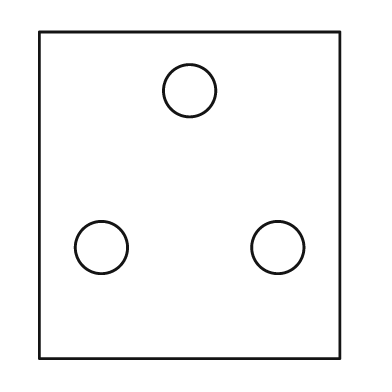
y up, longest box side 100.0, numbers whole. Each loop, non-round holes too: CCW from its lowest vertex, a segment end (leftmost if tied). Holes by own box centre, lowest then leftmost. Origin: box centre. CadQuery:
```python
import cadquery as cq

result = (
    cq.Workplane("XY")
    .moveTo(-46.0, -50.0)
    .lineTo(46.0, -50.0)
    .lineTo(46.0, 50.0)
    .lineTo(-46.0, 50.0)
    .close()
    .moveTo(-27.0, -16.0)
    .circle(8.0)
    .moveTo(27.0, -16.0)
    .circle(8.0)
    .moveTo(0.0, 32.0)
    .circle(8.0)
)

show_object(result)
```